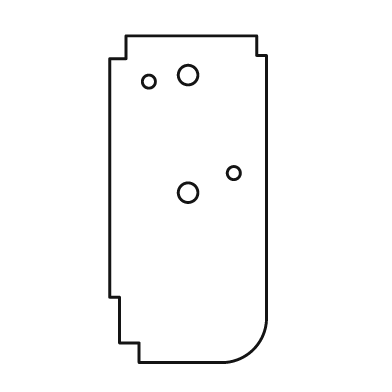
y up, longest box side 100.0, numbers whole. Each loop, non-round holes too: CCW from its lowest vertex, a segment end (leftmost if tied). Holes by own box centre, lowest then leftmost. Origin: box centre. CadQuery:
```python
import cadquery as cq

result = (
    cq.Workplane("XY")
    .moveTo(-15.0, -50.0)
    .lineTo(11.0, -50.0)
    .threePointArc((20.0, -46.0), (24.0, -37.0))
    .lineTo(24.0, 44.0)
    .lineTo(21.0, 44.0)
    .lineTo(21.0, 50.0)
    .lineTo(-19.0, 50.0)
    .lineTo(-19.0, 43.0)
    .lineTo(-24.0, 43.0)
    .lineTo(-24.0, -30.0)
    .lineTo(-21.0, -30.0)
    .lineTo(-21.0, -44.0)
    .lineTo(-15.0, -44.0)
    .close()
    .moveTo(0.0, 2.0)
    .circle(3.0)
    .moveTo(14.0, 8.0)
    .circle(2.0)
    .moveTo(-12.0, 36.0)
    .circle(2.0)
    .moveTo(0.0, 38.0)
    .circle(3.0)
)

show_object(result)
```